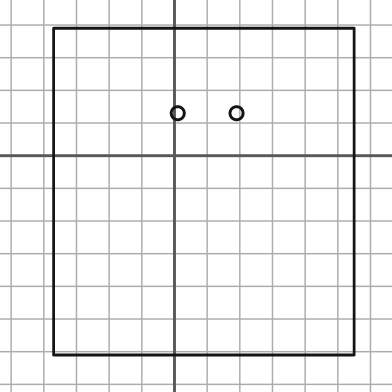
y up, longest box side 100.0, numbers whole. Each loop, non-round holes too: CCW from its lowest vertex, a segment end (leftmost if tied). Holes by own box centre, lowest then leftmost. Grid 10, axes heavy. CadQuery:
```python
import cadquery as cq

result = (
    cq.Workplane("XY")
    .moveTo(-37.0, -61.0)
    .lineTo(55.0, -61.0)
    .lineTo(55.0, 39.0)
    .lineTo(-37.0, 39.0)
    .close()
    .moveTo(1.0, 13.0)
    .circle(2.0)
    .moveTo(19.0, 13.0)
    .circle(2.0)
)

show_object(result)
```